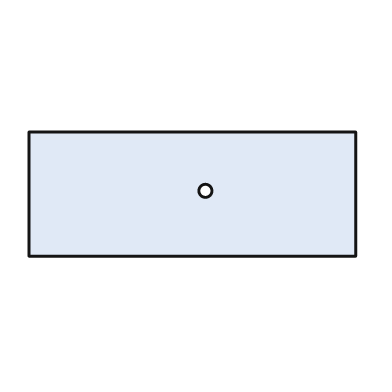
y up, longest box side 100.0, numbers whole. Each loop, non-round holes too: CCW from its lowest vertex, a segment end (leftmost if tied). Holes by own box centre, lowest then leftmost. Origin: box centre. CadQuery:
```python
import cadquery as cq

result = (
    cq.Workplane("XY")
    .moveTo(-50.0, -19.0)
    .lineTo(50.0, -19.0)
    .lineTo(50.0, 19.0)
    .lineTo(-50.0, 19.0)
    .close()
    .moveTo(4.0, 1.0)
    .circle(2.0)
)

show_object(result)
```